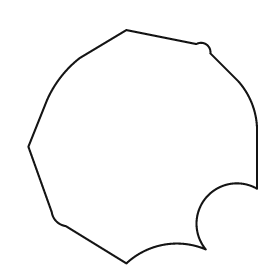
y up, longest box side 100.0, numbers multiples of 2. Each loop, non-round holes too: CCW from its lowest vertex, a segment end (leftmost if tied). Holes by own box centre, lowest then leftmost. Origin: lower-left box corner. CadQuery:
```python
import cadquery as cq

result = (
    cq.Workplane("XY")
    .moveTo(42.0, 0.0)
    .threePointArc((58.0, 8.0), (76.0, 6.0))
    .threePointArc((76.0, 28.0), (98.0, 32.0))
    .lineTo(98.0, 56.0)
    .threePointArc((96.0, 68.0), (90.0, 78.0))
    .lineTo(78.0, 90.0)
    .threePointArc((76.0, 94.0), (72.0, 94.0))
    .lineTo(42.0, 100.0)
    .lineTo(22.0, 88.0)
    .threePointArc((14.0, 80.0), (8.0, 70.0))
    .lineTo(0.0, 50.0)
    .lineTo(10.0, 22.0)
    .threePointArc((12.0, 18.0), (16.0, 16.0))
    .close()
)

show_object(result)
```